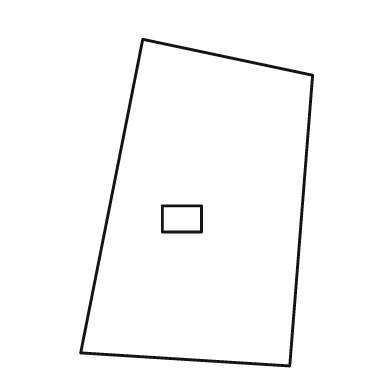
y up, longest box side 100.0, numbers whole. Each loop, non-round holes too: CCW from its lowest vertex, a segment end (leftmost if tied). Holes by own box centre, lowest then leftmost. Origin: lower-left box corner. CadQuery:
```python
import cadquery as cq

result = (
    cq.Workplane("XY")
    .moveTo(64.0, 0.0)
    .lineTo(71.0, 89.0)
    .lineTo(19.0, 100.0)
    .lineTo(0.0, 4.0)
    .close()
    .moveTo(25.0, 41.0)
    .lineTo(37.0, 41.0)
    .lineTo(37.0, 49.0)
    .lineTo(25.0, 49.0)
    .close()
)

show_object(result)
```